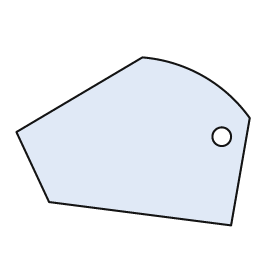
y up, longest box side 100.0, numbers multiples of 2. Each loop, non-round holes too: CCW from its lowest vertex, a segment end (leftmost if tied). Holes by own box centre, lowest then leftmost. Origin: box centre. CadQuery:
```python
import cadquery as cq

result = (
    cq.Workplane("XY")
    .moveTo(42.0, -36.0)
    .lineTo(50.0, 10.0)
    .threePointArc((30.0, 28.0), (4.0, 36.0))
    .lineTo(-50.0, 4.0)
    .lineTo(-36.0, -26.0)
    .close()
    .moveTo(38.0, 2.0)
    .circle(4.0)
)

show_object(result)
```